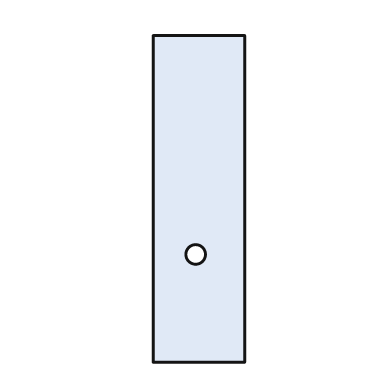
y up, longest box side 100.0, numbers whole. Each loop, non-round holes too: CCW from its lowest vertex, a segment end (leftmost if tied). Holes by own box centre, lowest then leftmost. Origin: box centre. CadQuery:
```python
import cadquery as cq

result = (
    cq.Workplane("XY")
    .moveTo(-14.0, -50.0)
    .lineTo(14.0, -50.0)
    .lineTo(14.0, 50.0)
    .lineTo(-14.0, 50.0)
    .close()
    .moveTo(-1.0, -17.0)
    .circle(3.0)
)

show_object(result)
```